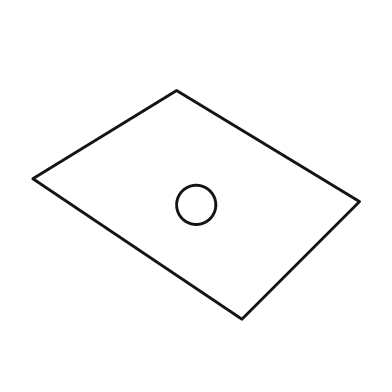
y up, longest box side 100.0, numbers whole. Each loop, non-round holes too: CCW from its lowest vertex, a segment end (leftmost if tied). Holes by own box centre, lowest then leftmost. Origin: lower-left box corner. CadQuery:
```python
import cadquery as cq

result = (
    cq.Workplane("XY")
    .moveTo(64.0, 0.0)
    .lineTo(100.0, 36.0)
    .lineTo(44.0, 70.0)
    .lineTo(0.0, 43.0)
    .close()
    .moveTo(50.0, 35.0)
    .circle(6.0)
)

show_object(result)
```